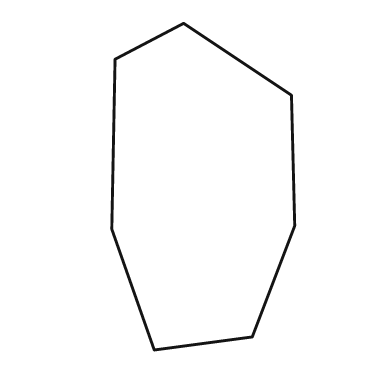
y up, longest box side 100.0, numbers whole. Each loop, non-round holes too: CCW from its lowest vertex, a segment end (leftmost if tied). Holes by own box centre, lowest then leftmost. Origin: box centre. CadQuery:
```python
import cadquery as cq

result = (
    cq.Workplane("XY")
    .moveTo(-15.0, -50.0)
    .lineTo(15.0, -46.0)
    .lineTo(28.0, -12.0)
    .lineTo(27.0, 28.0)
    .lineTo(-6.0, 50.0)
    .lineTo(-27.0, 39.0)
    .lineTo(-28.0, -13.0)
    .close()
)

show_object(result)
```